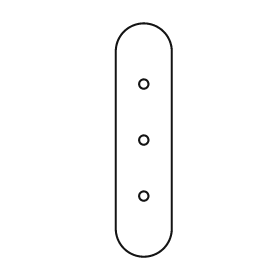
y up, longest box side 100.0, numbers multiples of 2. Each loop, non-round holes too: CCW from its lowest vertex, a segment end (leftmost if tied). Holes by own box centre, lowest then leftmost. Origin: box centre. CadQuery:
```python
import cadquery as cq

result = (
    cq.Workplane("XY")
    .moveTo(-12.0, -38.0)
    .threePointArc((0.0, -50.0), (12.0, -38.0))
    .lineTo(12.0, 38.0)
    .threePointArc((0.0, 50.0), (-12.0, 38.0))
    .close()
    .moveTo(0.0, -24.0)
    .circle(2.0)
    .moveTo(0.0, 0.0)
    .circle(2.0)
    .moveTo(0.0, 24.0)
    .circle(2.0)
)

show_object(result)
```